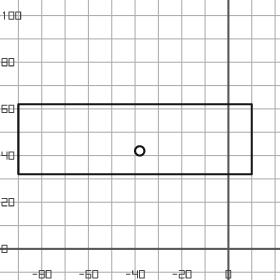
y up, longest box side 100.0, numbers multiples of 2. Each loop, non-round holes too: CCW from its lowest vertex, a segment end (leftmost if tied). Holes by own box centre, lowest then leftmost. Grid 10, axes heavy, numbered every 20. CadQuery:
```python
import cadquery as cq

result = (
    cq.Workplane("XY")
    .moveTo(-90.0, 32.0)
    .lineTo(10.0, 32.0)
    .lineTo(10.0, 62.0)
    .lineTo(-90.0, 62.0)
    .close()
    .moveTo(-38.0, 42.0)
    .circle(2.0)
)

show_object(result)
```